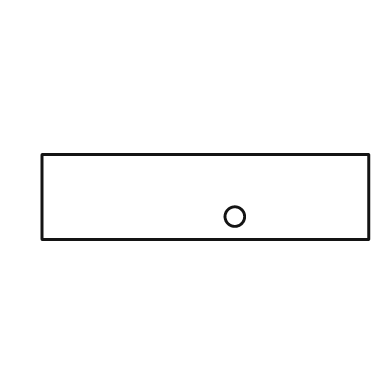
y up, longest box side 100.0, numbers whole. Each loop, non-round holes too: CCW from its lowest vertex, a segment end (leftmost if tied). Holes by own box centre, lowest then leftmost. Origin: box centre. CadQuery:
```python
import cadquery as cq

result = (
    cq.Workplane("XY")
    .moveTo(-50.0, -13.0)
    .lineTo(50.0, -13.0)
    .lineTo(50.0, 13.0)
    .lineTo(-50.0, 13.0)
    .close()
    .moveTo(9.0, -6.0)
    .circle(3.0)
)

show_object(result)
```